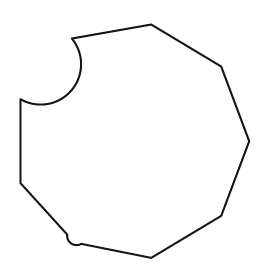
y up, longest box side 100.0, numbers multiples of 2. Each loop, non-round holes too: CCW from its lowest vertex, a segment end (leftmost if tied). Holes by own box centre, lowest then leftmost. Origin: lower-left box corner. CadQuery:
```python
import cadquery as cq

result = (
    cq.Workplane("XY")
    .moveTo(56.0, 0.0)
    .lineTo(86.0, 18.0)
    .lineTo(98.0, 50.0)
    .lineTo(86.0, 82.0)
    .lineTo(56.0, 100.0)
    .lineTo(22.0, 94.0)
    .threePointArc((22.0, 72.0), (0.0, 68.0))
    .lineTo(0.0, 32.0)
    .lineTo(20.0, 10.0)
    .threePointArc((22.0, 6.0), (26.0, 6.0))
    .close()
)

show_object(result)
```